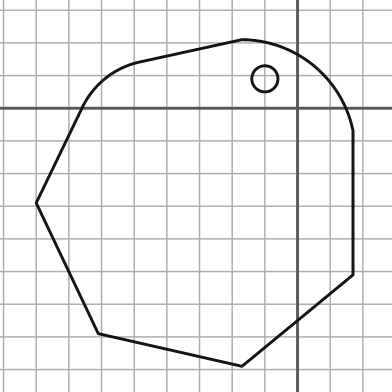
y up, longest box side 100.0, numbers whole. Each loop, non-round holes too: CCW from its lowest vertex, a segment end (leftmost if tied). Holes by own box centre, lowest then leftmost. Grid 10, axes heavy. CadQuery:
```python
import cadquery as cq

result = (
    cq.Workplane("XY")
    .moveTo(-17.0, -79.0)
    .lineTo(17.0, -51.0)
    .lineTo(17.0, -7.0)
    .threePointArc((5.0, 13.0), (-17.0, 21.0))
    .lineTo(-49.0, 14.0)
    .threePointArc((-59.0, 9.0), (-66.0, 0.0))
    .lineTo(-80.0, -29.0)
    .lineTo(-61.0, -69.0)
    .close()
    .moveTo(-10.0, 9.0)
    .circle(4.0)
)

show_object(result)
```